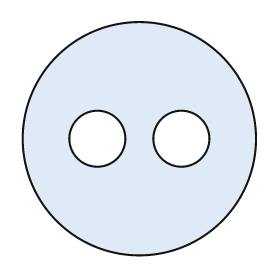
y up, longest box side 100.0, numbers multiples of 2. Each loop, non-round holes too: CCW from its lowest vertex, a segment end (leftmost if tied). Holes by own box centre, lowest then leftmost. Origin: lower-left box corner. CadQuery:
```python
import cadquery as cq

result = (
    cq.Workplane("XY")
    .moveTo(50.0, 50.0)
    .circle(50.0)
    .moveTo(32.0, 50.0)
    .circle(12.0)
    .moveTo(68.0, 50.0)
    .circle(12.0)
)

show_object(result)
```